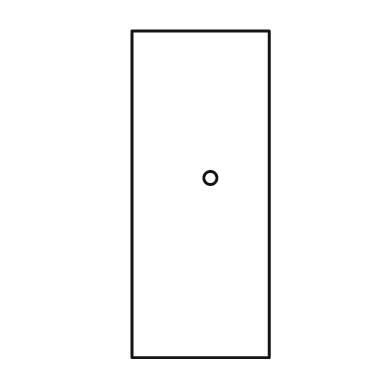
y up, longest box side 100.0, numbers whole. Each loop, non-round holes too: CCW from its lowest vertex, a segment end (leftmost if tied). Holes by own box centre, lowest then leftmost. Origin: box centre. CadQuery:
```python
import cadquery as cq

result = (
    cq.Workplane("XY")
    .moveTo(-21.0, -50.0)
    .lineTo(21.0, -50.0)
    .lineTo(21.0, 50.0)
    .lineTo(-21.0, 50.0)
    .close()
    .moveTo(3.0, 5.0)
    .circle(2.0)
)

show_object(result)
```